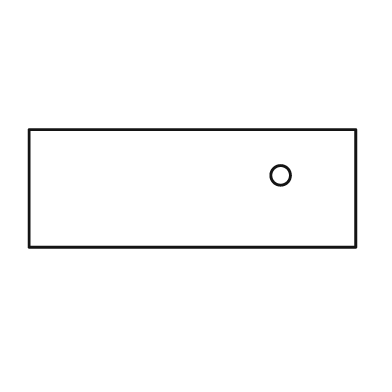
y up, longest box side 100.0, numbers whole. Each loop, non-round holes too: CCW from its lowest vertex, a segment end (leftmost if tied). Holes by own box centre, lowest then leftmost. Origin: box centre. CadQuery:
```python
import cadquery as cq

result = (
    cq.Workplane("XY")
    .moveTo(-50.0, -18.0)
    .lineTo(50.0, -18.0)
    .lineTo(50.0, 18.0)
    .lineTo(-50.0, 18.0)
    .close()
    .moveTo(27.0, 4.0)
    .circle(3.0)
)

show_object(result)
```